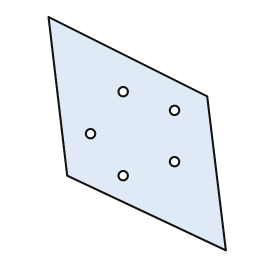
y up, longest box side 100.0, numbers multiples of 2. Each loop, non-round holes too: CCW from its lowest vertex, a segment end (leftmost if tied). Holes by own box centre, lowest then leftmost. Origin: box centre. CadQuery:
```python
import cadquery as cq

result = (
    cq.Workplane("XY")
    .moveTo(38.0, -50.0)
    .lineTo(30.0, 16.0)
    .lineTo(-38.0, 50.0)
    .lineTo(-30.0, -18.0)
    .close()
    .moveTo(-6.0, -18.0)
    .circle(2.0)
    .moveTo(16.0, -12.0)
    .circle(2.0)
    .moveTo(-20.0, 0.0)
    .circle(2.0)
    .moveTo(16.0, 10.0)
    .circle(2.0)
    .moveTo(-6.0, 18.0)
    .circle(2.0)
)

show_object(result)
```